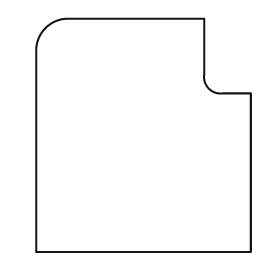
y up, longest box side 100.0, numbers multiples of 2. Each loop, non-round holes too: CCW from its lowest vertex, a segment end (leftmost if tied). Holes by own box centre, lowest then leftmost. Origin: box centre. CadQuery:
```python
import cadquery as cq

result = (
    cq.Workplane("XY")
    .moveTo(-46.0, -50.0)
    .lineTo(46.0, -50.0)
    .lineTo(46.0, 18.0)
    .lineTo(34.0, 18.0)
    .threePointArc((28.0, 20.0), (26.0, 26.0))
    .lineTo(26.0, 50.0)
    .lineTo(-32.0, 50.0)
    .threePointArc((-42.0, 46.0), (-46.0, 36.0))
    .close()
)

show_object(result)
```